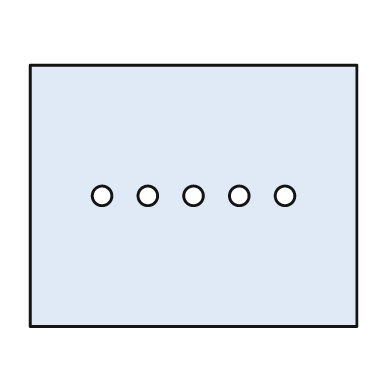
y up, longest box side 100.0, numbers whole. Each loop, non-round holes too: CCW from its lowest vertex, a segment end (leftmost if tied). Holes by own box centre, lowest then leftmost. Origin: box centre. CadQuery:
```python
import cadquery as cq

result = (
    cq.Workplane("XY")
    .moveTo(-50.0, -40.0)
    .lineTo(50.0, -40.0)
    .lineTo(50.0, 40.0)
    .lineTo(-50.0, 40.0)
    .close()
    .moveTo(-28.0, 0.0)
    .circle(3.0)
    .moveTo(-14.0, 0.0)
    .circle(3.0)
    .moveTo(0.0, 0.0)
    .circle(3.0)
    .moveTo(14.0, 0.0)
    .circle(3.0)
    .moveTo(28.0, 0.0)
    .circle(3.0)
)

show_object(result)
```